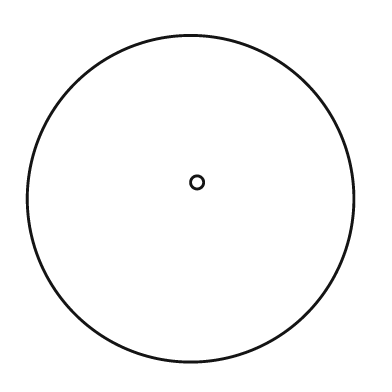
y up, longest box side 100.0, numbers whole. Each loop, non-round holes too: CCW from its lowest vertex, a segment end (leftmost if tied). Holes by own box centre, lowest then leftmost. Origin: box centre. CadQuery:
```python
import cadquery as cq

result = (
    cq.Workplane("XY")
    .moveTo(0.0, 0.0)
    .circle(50.0)
    .moveTo(2.0, 5.0)
    .circle(2.0)
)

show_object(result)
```